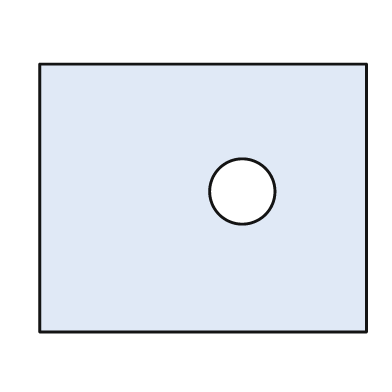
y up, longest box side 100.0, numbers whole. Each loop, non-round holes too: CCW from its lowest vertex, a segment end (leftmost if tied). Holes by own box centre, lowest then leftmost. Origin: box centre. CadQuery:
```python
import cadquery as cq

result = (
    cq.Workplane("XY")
    .moveTo(-50.0, -41.0)
    .lineTo(50.0, -41.0)
    .lineTo(50.0, 41.0)
    .lineTo(-50.0, 41.0)
    .close()
    .moveTo(12.0, 2.0)
    .circle(10.0)
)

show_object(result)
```